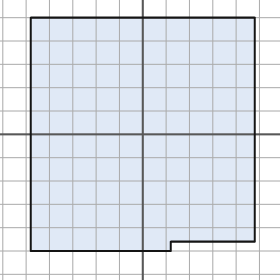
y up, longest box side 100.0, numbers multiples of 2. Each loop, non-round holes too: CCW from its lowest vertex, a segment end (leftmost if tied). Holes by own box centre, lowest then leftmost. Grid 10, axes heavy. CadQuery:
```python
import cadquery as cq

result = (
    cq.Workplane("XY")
    .moveTo(-48.0, -50.0)
    .lineTo(12.0, -50.0)
    .lineTo(12.0, -46.0)
    .lineTo(48.0, -46.0)
    .lineTo(48.0, 50.0)
    .lineTo(-48.0, 50.0)
    .close()
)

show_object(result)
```